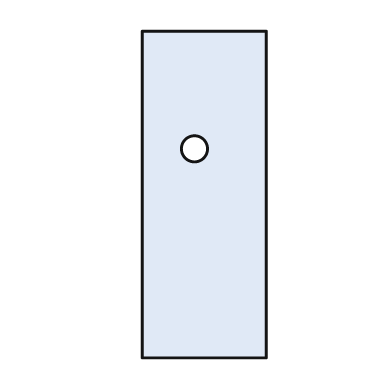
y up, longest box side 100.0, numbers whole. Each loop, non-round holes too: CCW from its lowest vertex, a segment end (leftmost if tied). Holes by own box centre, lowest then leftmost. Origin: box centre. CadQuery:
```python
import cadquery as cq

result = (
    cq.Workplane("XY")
    .moveTo(-19.0, -50.0)
    .lineTo(19.0, -50.0)
    .lineTo(19.0, 50.0)
    .lineTo(-19.0, 50.0)
    .close()
    .moveTo(-3.0, 14.0)
    .circle(4.0)
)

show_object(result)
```